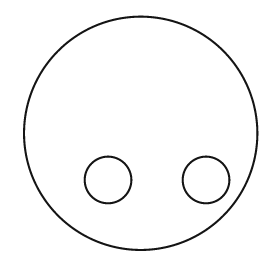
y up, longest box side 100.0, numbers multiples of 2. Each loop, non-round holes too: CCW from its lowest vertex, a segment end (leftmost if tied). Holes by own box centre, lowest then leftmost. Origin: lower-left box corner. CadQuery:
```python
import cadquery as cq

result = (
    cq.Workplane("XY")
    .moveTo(50.0, 50.0)
    .circle(50.0)
    .moveTo(36.0, 30.0)
    .circle(10.0)
    .moveTo(78.0, 30.0)
    .circle(10.0)
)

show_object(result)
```